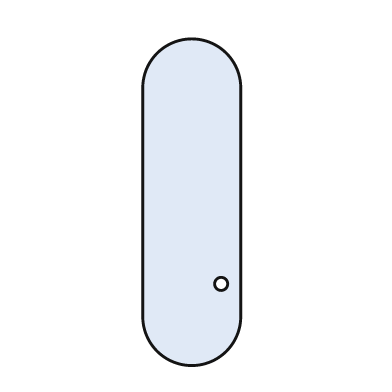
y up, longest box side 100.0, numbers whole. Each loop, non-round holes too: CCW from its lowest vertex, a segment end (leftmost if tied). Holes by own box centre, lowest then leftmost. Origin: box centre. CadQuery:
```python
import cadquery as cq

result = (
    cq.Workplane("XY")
    .moveTo(-15.0, -35.0)
    .threePointArc((0.0, -50.0), (15.0, -35.0))
    .lineTo(15.0, 35.0)
    .threePointArc((0.0, 50.0), (-15.0, 35.0))
    .close()
    .moveTo(9.0, -25.0)
    .circle(2.0)
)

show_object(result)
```